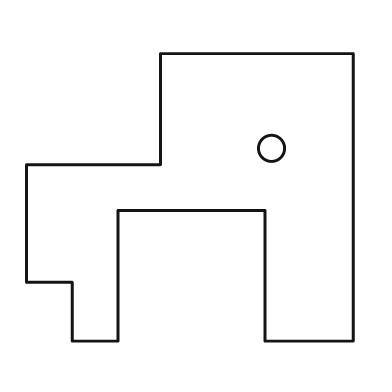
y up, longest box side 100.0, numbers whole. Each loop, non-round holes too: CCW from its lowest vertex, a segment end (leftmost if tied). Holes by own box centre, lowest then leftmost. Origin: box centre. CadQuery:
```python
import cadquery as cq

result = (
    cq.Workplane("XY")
    .moveTo(-36.0, -44.0)
    .lineTo(-22.0, -44.0)
    .lineTo(-22.0, -4.0)
    .lineTo(23.0, -4.0)
    .lineTo(23.0, -44.0)
    .lineTo(50.0, -44.0)
    .lineTo(50.0, 44.0)
    .lineTo(-9.0, 44.0)
    .lineTo(-9.0, 10.0)
    .lineTo(-50.0, 10.0)
    .lineTo(-50.0, -26.0)
    .lineTo(-36.0, -26.0)
    .close()
    .moveTo(25.0, 15.0)
    .circle(4.0)
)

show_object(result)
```